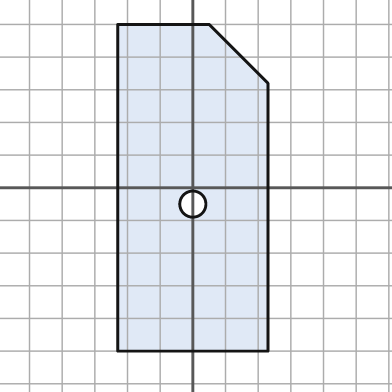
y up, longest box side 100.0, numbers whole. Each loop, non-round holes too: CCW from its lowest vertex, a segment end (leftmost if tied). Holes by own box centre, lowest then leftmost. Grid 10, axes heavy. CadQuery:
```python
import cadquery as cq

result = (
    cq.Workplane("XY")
    .moveTo(-23.0, -50.0)
    .lineTo(23.0, -50.0)
    .lineTo(23.0, 32.0)
    .lineTo(5.0, 50.0)
    .lineTo(-23.0, 50.0)
    .close()
    .moveTo(0.0, -5.0)
    .circle(4.0)
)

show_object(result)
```